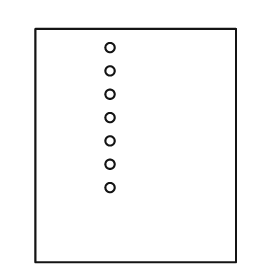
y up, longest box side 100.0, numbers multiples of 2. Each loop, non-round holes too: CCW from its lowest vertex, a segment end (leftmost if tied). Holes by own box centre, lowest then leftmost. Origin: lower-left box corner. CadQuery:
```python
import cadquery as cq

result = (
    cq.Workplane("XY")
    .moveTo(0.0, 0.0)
    .lineTo(86.0, 0.0)
    .lineTo(86.0, 100.0)
    .lineTo(0.0, 100.0)
    .close()
    .moveTo(32.0, 32.0)
    .circle(2.0)
    .moveTo(32.0, 42.0)
    .circle(2.0)
    .moveTo(32.0, 52.0)
    .circle(2.0)
    .moveTo(32.0, 62.0)
    .circle(2.0)
    .moveTo(32.0, 72.0)
    .circle(2.0)
    .moveTo(32.0, 82.0)
    .circle(2.0)
    .moveTo(32.0, 92.0)
    .circle(2.0)
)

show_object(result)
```